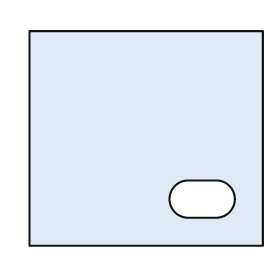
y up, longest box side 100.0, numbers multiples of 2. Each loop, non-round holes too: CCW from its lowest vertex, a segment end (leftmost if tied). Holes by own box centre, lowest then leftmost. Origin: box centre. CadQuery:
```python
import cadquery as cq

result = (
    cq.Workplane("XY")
    .moveTo(-50.0, -46.0)
    .lineTo(50.0, -46.0)
    .lineTo(50.0, 46.0)
    .lineTo(-50.0, 46.0)
    .close()
    .moveTo(18.0, -34.0)
    .lineTo(30.0, -34.0)
    .threePointArc((38.0, -26.0), (30.0, -18.0))
    .lineTo(18.0, -18.0)
    .threePointArc((10.0, -26.0), (18.0, -34.0))
    .close()
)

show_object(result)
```